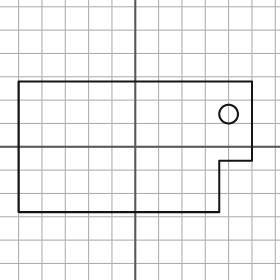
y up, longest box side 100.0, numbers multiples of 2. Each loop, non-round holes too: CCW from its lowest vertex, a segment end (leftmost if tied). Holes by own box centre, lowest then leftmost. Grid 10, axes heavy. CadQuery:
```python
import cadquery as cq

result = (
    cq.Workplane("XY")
    .moveTo(-50.0, -28.0)
    .lineTo(36.0, -28.0)
    .lineTo(36.0, -6.0)
    .lineTo(50.0, -6.0)
    .lineTo(50.0, 28.0)
    .lineTo(-50.0, 28.0)
    .close()
    .moveTo(40.0, 14.0)
    .circle(4.0)
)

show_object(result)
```